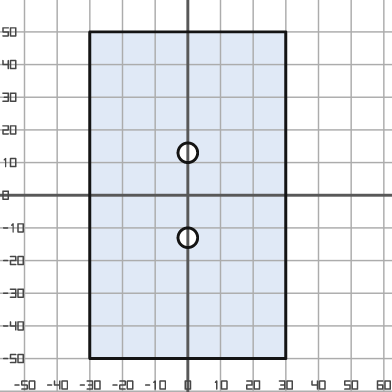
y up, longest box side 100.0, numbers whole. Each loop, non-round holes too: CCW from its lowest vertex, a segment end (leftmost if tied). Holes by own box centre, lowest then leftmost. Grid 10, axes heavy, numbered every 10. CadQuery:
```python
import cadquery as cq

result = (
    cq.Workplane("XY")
    .moveTo(-30.0, -50.0)
    .lineTo(30.0, -50.0)
    .lineTo(30.0, 50.0)
    .lineTo(-30.0, 50.0)
    .close()
    .moveTo(0.0, -13.0)
    .circle(3.0)
    .moveTo(0.0, 13.0)
    .circle(3.0)
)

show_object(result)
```